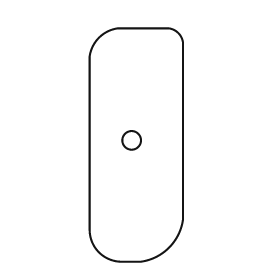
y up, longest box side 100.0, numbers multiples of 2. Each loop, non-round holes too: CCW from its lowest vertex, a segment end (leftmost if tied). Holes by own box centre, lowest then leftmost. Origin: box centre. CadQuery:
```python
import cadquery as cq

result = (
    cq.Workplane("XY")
    .moveTo(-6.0, -50.0)
    .lineTo(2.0, -50.0)
    .threePointArc((14.0, -44.0), (20.0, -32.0))
    .lineTo(20.0, 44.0)
    .threePointArc((18.0, 48.0), (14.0, 50.0))
    .lineTo(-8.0, 50.0)
    .threePointArc((-16.0, 46.0), (-20.0, 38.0))
    .lineTo(-20.0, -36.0)
    .threePointArc((-16.0, -46.0), (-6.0, -50.0))
    .close()
    .moveTo(-2.0, 2.0)
    .circle(4.0)
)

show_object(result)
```